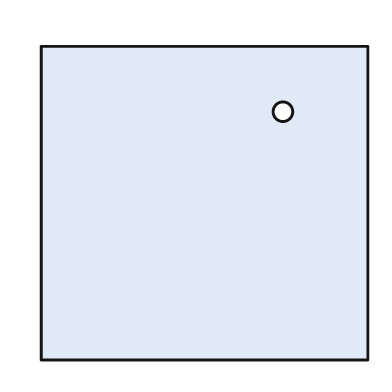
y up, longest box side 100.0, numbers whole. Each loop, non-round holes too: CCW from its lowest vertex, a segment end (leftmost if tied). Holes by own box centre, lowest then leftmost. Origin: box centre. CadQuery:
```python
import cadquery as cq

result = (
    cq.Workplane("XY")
    .moveTo(-50.0, -48.0)
    .lineTo(50.0, -48.0)
    .lineTo(50.0, 48.0)
    .lineTo(-50.0, 48.0)
    .close()
    .moveTo(24.0, 28.0)
    .circle(3.0)
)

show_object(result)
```